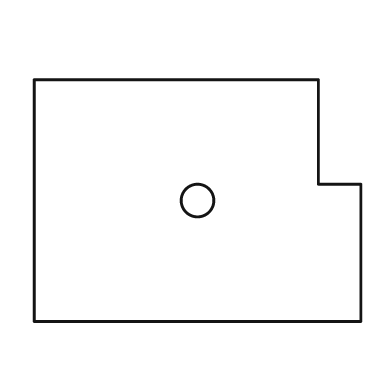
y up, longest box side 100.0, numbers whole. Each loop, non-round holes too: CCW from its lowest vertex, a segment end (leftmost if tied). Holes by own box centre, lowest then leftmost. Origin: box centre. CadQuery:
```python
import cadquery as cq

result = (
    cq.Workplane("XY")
    .moveTo(-50.0, -37.0)
    .lineTo(50.0, -37.0)
    .lineTo(50.0, 5.0)
    .lineTo(37.0, 5.0)
    .lineTo(37.0, 37.0)
    .lineTo(-50.0, 37.0)
    .close()
    .moveTo(0.0, 0.0)
    .circle(5.0)
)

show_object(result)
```